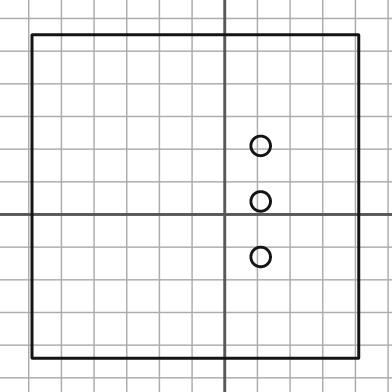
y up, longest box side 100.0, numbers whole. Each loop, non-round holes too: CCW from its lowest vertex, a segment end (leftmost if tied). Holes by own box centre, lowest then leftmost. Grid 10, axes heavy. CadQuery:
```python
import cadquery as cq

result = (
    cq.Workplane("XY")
    .moveTo(-59.0, -44.0)
    .lineTo(41.0, -44.0)
    .lineTo(41.0, 55.0)
    .lineTo(-59.0, 55.0)
    .close()
    .moveTo(11.0, -13.0)
    .circle(3.0)
    .moveTo(11.0, 4.0)
    .circle(3.0)
    .moveTo(11.0, 21.0)
    .circle(3.0)
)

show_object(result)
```